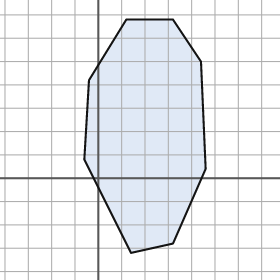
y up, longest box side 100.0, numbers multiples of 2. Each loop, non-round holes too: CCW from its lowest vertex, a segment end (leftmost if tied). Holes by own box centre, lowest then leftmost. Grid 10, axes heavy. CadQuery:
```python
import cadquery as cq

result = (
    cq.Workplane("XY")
    .moveTo(14.0, -32.0)
    .lineTo(32.0, -28.0)
    .lineTo(46.0, 4.0)
    .lineTo(44.0, 50.0)
    .lineTo(32.0, 68.0)
    .lineTo(12.0, 68.0)
    .lineTo(-4.0, 42.0)
    .lineTo(-6.0, 8.0)
    .close()
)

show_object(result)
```